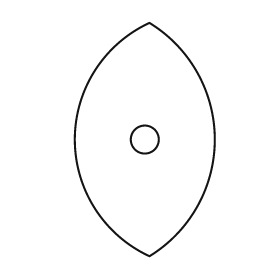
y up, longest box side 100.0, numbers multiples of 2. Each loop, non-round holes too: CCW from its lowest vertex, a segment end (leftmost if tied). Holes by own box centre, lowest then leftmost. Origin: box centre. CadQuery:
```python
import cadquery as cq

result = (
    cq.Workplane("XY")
    .moveTo(2.0, -50.0)
    .threePointArc((30.0, 0.0), (2.0, 50.0))
    .threePointArc((-30.0, 0.0), (2.0, -50.0))
    .close()
    .moveTo(0.0, 0.0)
    .circle(6.0)
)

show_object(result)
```